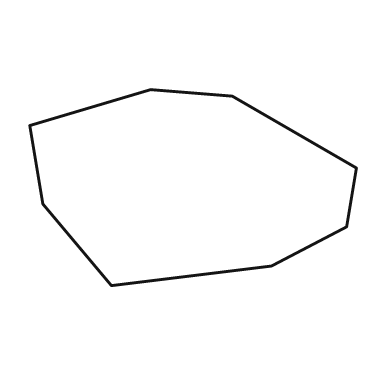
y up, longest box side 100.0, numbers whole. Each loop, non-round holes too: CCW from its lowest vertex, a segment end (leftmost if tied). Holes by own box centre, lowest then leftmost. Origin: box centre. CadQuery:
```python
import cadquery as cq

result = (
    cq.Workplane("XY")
    .moveTo(-25.0, -30.0)
    .lineTo(24.0, -24.0)
    .lineTo(47.0, -12.0)
    .lineTo(50.0, 6.0)
    .lineTo(12.0, 28.0)
    .lineTo(-13.0, 30.0)
    .lineTo(-50.0, 19.0)
    .lineTo(-46.0, -5.0)
    .close()
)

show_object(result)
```